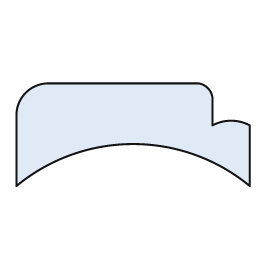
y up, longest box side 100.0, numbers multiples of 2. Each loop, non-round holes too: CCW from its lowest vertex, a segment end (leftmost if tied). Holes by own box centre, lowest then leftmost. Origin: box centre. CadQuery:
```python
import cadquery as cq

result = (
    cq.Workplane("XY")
    .moveTo(-50.0, -22.0)
    .threePointArc((0.0, -4.0), (50.0, -22.0))
    .lineTo(50.0, 4.0)
    .threePointArc((42.0, 6.0), (34.0, 4.0))
    .lineTo(34.0, 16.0)
    .threePointArc((32.0, 20.0), (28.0, 22.0))
    .lineTo(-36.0, 22.0)
    .threePointArc((-46.0, 18.0), (-50.0, 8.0))
    .close()
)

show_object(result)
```